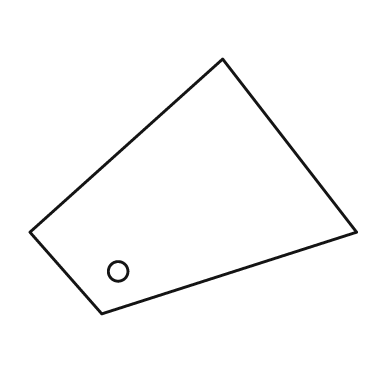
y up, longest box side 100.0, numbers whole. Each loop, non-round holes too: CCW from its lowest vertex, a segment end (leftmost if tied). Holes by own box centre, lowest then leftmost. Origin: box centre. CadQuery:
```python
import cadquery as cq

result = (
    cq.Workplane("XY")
    .moveTo(-28.0, -39.0)
    .lineTo(50.0, -14.0)
    .lineTo(9.0, 39.0)
    .lineTo(-50.0, -14.0)
    .close()
    .moveTo(-23.0, -26.0)
    .circle(3.0)
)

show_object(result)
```